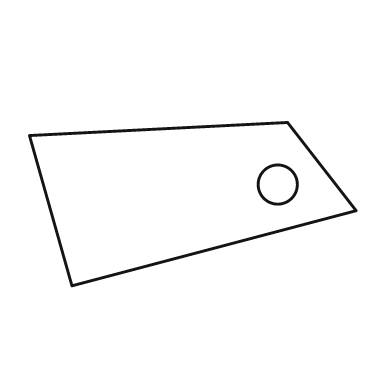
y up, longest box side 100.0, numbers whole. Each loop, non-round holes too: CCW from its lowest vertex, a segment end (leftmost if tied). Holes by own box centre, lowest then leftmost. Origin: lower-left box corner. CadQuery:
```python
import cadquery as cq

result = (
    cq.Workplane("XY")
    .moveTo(13.0, 0.0)
    .lineTo(100.0, 23.0)
    .lineTo(79.0, 50.0)
    .lineTo(0.0, 46.0)
    .close()
    .moveTo(76.0, 31.0)
    .circle(6.0)
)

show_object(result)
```